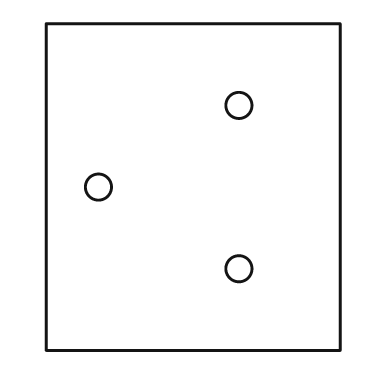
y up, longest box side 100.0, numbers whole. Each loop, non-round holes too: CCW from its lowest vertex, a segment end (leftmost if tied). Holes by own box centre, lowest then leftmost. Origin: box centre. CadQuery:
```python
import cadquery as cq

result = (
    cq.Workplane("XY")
    .moveTo(-45.0, -50.0)
    .lineTo(45.0, -50.0)
    .lineTo(45.0, 50.0)
    .lineTo(-45.0, 50.0)
    .close()
    .moveTo(14.0, -25.0)
    .circle(4.0)
    .moveTo(-29.0, 0.0)
    .circle(4.0)
    .moveTo(14.0, 25.0)
    .circle(4.0)
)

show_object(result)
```